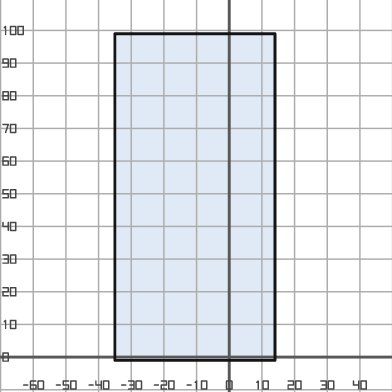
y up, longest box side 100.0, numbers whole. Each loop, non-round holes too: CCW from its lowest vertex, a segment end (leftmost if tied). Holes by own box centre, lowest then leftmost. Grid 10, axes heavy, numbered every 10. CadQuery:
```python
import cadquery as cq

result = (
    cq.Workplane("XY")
    .moveTo(-35.0, -1.0)
    .lineTo(14.0, -1.0)
    .lineTo(14.0, 99.0)
    .lineTo(-35.0, 99.0)
    .close()
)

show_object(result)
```